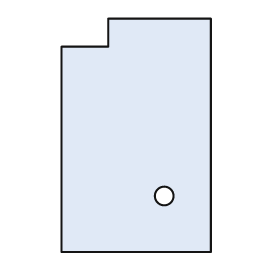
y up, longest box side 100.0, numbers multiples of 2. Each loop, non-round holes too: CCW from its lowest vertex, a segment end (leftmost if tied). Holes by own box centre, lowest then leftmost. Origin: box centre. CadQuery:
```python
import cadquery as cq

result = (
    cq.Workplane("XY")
    .moveTo(-32.0, -50.0)
    .lineTo(32.0, -50.0)
    .lineTo(32.0, 50.0)
    .lineTo(-12.0, 50.0)
    .lineTo(-12.0, 38.0)
    .lineTo(-32.0, 38.0)
    .close()
    .moveTo(12.0, -26.0)
    .circle(4.0)
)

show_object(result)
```